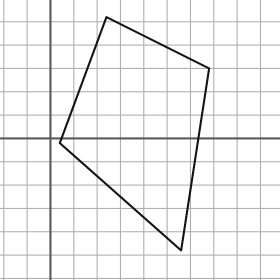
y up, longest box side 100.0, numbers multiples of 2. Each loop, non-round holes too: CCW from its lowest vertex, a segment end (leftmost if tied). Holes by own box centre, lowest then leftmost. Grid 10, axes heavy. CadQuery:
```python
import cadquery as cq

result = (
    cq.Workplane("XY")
    .moveTo(56.0, -48.0)
    .lineTo(68.0, 30.0)
    .lineTo(24.0, 52.0)
    .lineTo(4.0, -2.0)
    .close()
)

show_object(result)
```